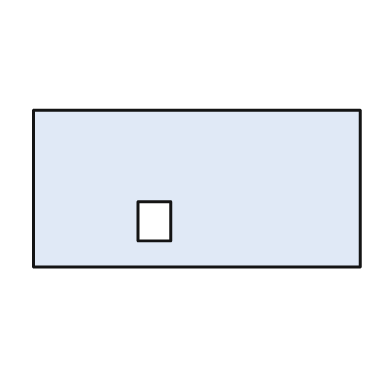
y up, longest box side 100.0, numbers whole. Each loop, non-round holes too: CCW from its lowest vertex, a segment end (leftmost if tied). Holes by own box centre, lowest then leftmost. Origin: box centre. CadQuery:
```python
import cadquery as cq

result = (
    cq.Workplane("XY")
    .moveTo(-50.0, -24.0)
    .lineTo(50.0, -24.0)
    .lineTo(50.0, 24.0)
    .lineTo(-50.0, 24.0)
    .close()
    .moveTo(-18.0, -16.0)
    .lineTo(-8.0, -16.0)
    .lineTo(-8.0, -4.0)
    .lineTo(-18.0, -4.0)
    .close()
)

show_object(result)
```